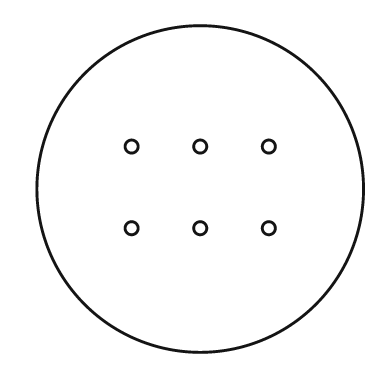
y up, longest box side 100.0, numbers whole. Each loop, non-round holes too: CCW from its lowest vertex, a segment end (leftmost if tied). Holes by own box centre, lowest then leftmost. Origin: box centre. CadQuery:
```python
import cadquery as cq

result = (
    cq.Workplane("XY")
    .moveTo(0.0, 0.0)
    .circle(50.0)
    .moveTo(-21.0, -12.0)
    .circle(2.0)
    .moveTo(0.0, -12.0)
    .circle(2.0)
    .moveTo(21.0, -12.0)
    .circle(2.0)
    .moveTo(-21.0, 13.0)
    .circle(2.0)
    .moveTo(0.0, 13.0)
    .circle(2.0)
    .moveTo(21.0, 13.0)
    .circle(2.0)
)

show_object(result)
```